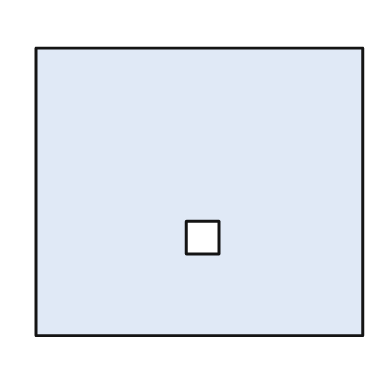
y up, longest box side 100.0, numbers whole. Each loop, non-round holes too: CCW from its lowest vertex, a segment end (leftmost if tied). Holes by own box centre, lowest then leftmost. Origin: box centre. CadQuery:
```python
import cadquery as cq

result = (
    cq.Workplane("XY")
    .moveTo(-50.0, -44.0)
    .lineTo(50.0, -44.0)
    .lineTo(50.0, 44.0)
    .lineTo(-50.0, 44.0)
    .close()
    .moveTo(-4.0, -19.0)
    .lineTo(6.0, -19.0)
    .lineTo(6.0, -9.0)
    .lineTo(-4.0, -9.0)
    .close()
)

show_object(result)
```